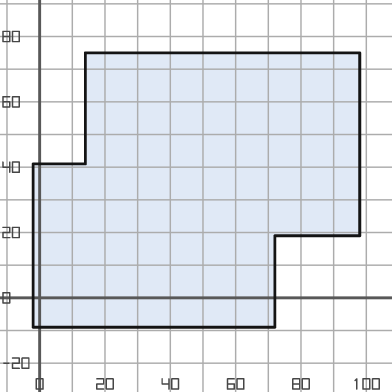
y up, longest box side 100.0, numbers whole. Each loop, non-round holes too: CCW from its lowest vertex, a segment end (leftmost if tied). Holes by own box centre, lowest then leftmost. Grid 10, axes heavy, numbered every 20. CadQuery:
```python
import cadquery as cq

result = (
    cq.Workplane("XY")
    .moveTo(-2.0, -9.0)
    .lineTo(72.0, -9.0)
    .lineTo(72.0, 19.0)
    .lineTo(98.0, 19.0)
    .lineTo(98.0, 75.0)
    .lineTo(14.0, 75.0)
    .lineTo(14.0, 41.0)
    .lineTo(-2.0, 41.0)
    .close()
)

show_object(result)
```